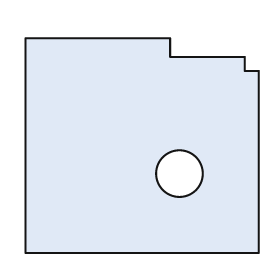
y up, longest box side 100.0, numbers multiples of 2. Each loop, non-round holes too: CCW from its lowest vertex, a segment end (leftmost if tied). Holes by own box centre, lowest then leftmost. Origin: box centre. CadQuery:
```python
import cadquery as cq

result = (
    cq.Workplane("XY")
    .moveTo(-50.0, -46.0)
    .lineTo(50.0, -46.0)
    .lineTo(50.0, 32.0)
    .lineTo(44.0, 32.0)
    .lineTo(44.0, 38.0)
    .lineTo(12.0, 38.0)
    .lineTo(12.0, 46.0)
    .lineTo(-50.0, 46.0)
    .close()
    .moveTo(16.0, -12.0)
    .circle(10.0)
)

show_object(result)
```